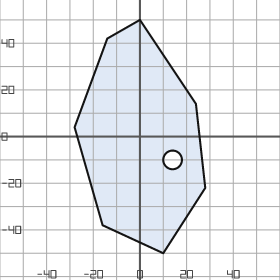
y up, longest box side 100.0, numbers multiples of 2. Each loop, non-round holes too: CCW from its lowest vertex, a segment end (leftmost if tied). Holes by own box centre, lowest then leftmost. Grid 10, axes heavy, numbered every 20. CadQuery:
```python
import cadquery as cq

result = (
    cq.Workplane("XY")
    .moveTo(10.0, -50.0)
    .lineTo(28.0, -22.0)
    .lineTo(24.0, 14.0)
    .lineTo(0.0, 50.0)
    .lineTo(-14.0, 42.0)
    .lineTo(-28.0, 4.0)
    .lineTo(-16.0, -38.0)
    .close()
    .moveTo(14.0, -10.0)
    .circle(4.0)
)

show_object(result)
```